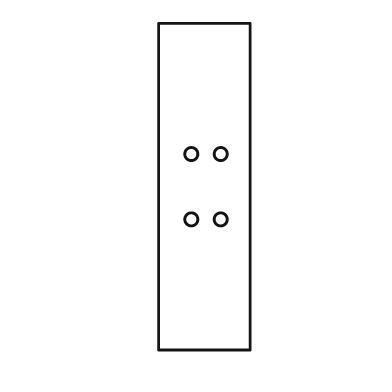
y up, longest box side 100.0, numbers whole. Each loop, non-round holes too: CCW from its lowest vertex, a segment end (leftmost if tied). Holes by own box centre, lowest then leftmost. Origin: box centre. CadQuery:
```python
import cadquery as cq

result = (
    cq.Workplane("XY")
    .moveTo(-14.0, -50.0)
    .lineTo(14.0, -50.0)
    .lineTo(14.0, 50.0)
    .lineTo(-14.0, 50.0)
    .close()
    .moveTo(-4.0, -10.0)
    .circle(2.0)
    .moveTo(5.0, -10.0)
    .circle(2.0)
    .moveTo(-4.0, 10.0)
    .circle(2.0)
    .moveTo(5.0, 10.0)
    .circle(2.0)
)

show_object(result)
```